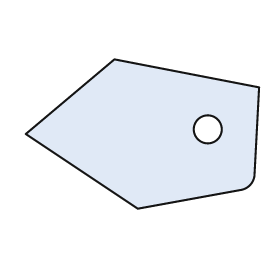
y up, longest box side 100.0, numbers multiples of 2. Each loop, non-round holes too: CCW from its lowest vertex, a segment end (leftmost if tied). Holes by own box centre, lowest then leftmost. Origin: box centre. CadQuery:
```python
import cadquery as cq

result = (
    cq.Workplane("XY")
    .moveTo(-2.0, -32.0)
    .lineTo(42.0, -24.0)
    .threePointArc((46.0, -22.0), (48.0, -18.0))
    .lineTo(50.0, 20.0)
    .lineTo(-12.0, 32.0)
    .lineTo(-50.0, 0.0)
    .close()
    .moveTo(28.0, 2.0)
    .circle(6.0)
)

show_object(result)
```